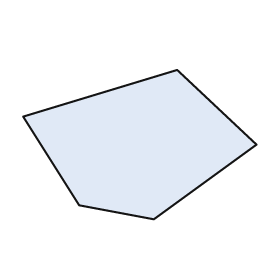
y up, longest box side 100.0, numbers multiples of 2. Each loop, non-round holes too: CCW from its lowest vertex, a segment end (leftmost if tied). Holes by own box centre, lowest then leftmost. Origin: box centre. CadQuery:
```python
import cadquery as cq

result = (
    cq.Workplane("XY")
    .moveTo(6.0, -32.0)
    .lineTo(50.0, 0.0)
    .lineTo(16.0, 32.0)
    .lineTo(-50.0, 12.0)
    .lineTo(-26.0, -26.0)
    .close()
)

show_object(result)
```